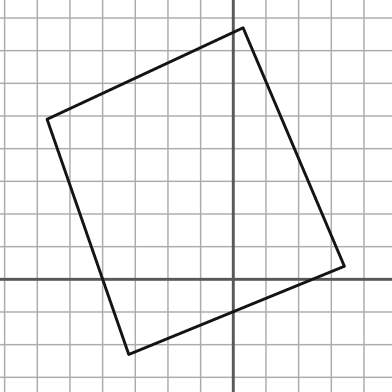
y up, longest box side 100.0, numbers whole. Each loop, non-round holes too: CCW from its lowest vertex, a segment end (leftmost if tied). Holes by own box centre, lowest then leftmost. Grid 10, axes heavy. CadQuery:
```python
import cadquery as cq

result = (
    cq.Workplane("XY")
    .moveTo(-32.0, -23.0)
    .lineTo(34.0, 4.0)
    .lineTo(3.0, 77.0)
    .lineTo(-57.0, 49.0)
    .close()
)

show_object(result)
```